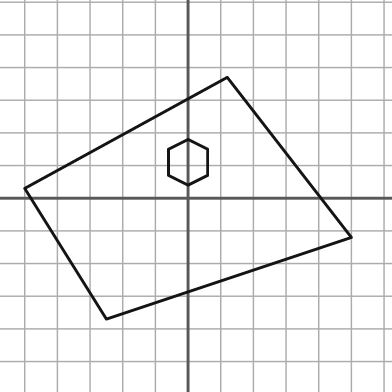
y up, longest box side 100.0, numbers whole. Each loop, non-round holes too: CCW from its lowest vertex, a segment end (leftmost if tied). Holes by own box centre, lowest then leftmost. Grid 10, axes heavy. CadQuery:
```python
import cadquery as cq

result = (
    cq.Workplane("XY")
    .moveTo(-25.0, -37.0)
    .lineTo(50.0, -12.0)
    .lineTo(12.0, 37.0)
    .lineTo(-50.0, 3.0)
    .close()
    .moveTo(0.0, 4.0)
    .lineTo(6.0, 7.0)
    .lineTo(6.0, 15.0)
    .lineTo(0.0, 18.0)
    .lineTo(-6.0, 15.0)
    .lineTo(-6.0, 7.0)
    .close()
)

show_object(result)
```